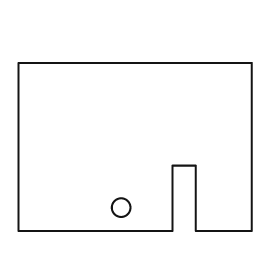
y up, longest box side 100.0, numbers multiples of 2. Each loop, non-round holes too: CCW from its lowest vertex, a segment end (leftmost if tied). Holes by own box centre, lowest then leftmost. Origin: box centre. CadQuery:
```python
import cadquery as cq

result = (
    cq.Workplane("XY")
    .moveTo(-50.0, -36.0)
    .lineTo(16.0, -36.0)
    .lineTo(16.0, -8.0)
    .lineTo(26.0, -8.0)
    .lineTo(26.0, -36.0)
    .lineTo(50.0, -36.0)
    .lineTo(50.0, 36.0)
    .lineTo(-50.0, 36.0)
    .close()
    .moveTo(-6.0, -26.0)
    .circle(4.0)
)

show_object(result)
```